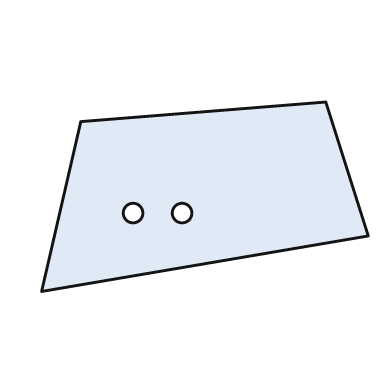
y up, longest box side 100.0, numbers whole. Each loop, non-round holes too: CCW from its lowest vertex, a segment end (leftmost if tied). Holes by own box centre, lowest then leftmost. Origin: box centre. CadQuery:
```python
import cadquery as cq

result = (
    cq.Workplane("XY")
    .moveTo(-50.0, -29.0)
    .lineTo(50.0, -12.0)
    .lineTo(37.0, 29.0)
    .lineTo(-38.0, 23.0)
    .close()
    .moveTo(-22.0, -5.0)
    .circle(3.0)
    .moveTo(-7.0, -5.0)
    .circle(3.0)
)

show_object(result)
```